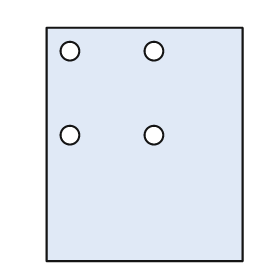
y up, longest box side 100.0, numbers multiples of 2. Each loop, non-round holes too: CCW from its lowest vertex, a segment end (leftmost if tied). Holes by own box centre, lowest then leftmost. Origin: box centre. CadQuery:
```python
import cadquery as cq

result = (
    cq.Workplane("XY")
    .moveTo(-42.0, -50.0)
    .lineTo(42.0, -50.0)
    .lineTo(42.0, 50.0)
    .lineTo(-42.0, 50.0)
    .close()
    .moveTo(-32.0, 4.0)
    .circle(4.0)
    .moveTo(4.0, 4.0)
    .circle(4.0)
    .moveTo(-32.0, 40.0)
    .circle(4.0)
    .moveTo(4.0, 40.0)
    .circle(4.0)
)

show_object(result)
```